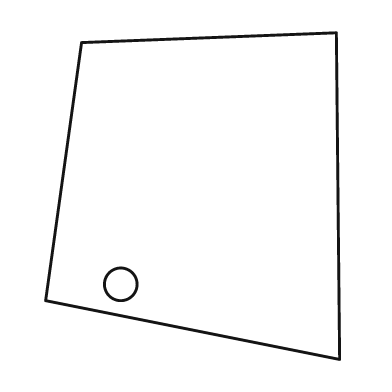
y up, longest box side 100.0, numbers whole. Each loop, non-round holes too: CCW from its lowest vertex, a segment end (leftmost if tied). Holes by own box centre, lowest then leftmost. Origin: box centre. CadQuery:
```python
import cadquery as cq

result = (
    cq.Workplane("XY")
    .moveTo(45.0, -50.0)
    .lineTo(44.0, 50.0)
    .lineTo(-34.0, 47.0)
    .lineTo(-45.0, -32.0)
    .close()
    .moveTo(-22.0, -27.0)
    .circle(5.0)
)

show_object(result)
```